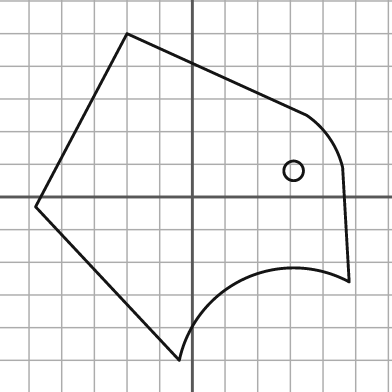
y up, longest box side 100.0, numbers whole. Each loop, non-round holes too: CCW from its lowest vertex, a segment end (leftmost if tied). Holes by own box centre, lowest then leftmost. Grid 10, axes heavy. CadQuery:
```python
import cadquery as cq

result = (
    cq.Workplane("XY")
    .moveTo(-4.0, -50.0)
    .threePointArc((16.0, -25.0), (48.0, -26.0))
    .lineTo(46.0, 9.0)
    .threePointArc((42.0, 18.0), (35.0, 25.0))
    .lineTo(-20.0, 50.0)
    .lineTo(-48.0, -3.0)
    .close()
    .moveTo(31.0, 8.0)
    .circle(3.0)
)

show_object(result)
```